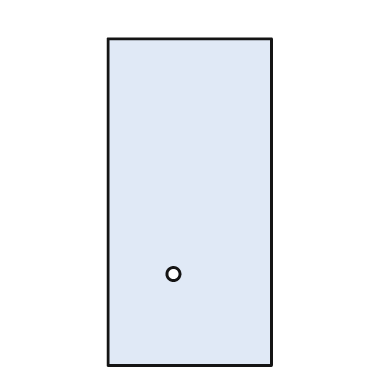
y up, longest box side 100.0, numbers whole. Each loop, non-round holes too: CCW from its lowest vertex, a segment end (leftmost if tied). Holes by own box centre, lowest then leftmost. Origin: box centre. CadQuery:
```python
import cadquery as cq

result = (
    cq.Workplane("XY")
    .moveTo(-25.0, -50.0)
    .lineTo(25.0, -50.0)
    .lineTo(25.0, 50.0)
    .lineTo(-25.0, 50.0)
    .close()
    .moveTo(-5.0, -22.0)
    .circle(2.0)
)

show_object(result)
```